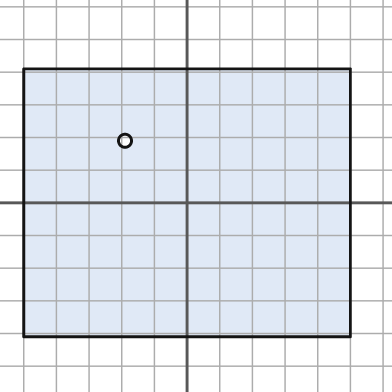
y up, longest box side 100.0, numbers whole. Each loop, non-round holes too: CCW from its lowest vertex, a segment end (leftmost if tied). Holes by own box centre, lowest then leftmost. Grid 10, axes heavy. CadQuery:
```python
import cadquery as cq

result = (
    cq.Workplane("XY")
    .moveTo(-50.0, -41.0)
    .lineTo(50.0, -41.0)
    .lineTo(50.0, 41.0)
    .lineTo(-50.0, 41.0)
    .close()
    .moveTo(-19.0, 19.0)
    .circle(2.0)
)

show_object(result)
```